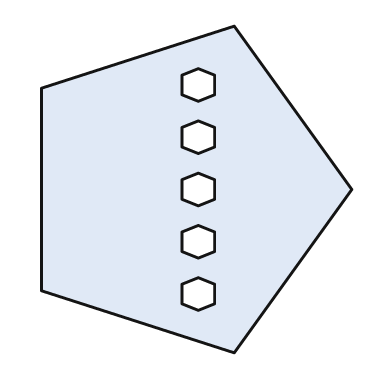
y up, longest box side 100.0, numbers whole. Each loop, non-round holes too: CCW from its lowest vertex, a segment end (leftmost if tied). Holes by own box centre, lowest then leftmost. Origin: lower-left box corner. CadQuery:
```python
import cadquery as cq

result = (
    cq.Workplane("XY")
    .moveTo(59.0, 0.0)
    .lineTo(95.0, 50.0)
    .lineTo(59.0, 100.0)
    .lineTo(0.0, 81.0)
    .lineTo(0.0, 19.0)
    .close()
    .moveTo(48.0, 13.0)
    .lineTo(53.0, 15.0)
    .lineTo(53.0, 21.0)
    .lineTo(48.0, 23.0)
    .lineTo(43.0, 21.0)
    .lineTo(43.0, 15.0)
    .close()
    .moveTo(48.0, 29.0)
    .lineTo(53.0, 31.0)
    .lineTo(53.0, 37.0)
    .lineTo(48.0, 39.0)
    .lineTo(43.0, 37.0)
    .lineTo(43.0, 31.0)
    .close()
    .moveTo(48.0, 45.0)
    .lineTo(53.0, 47.0)
    .lineTo(53.0, 53.0)
    .lineTo(48.0, 55.0)
    .lineTo(43.0, 53.0)
    .lineTo(43.0, 47.0)
    .close()
    .moveTo(48.0, 61.0)
    .lineTo(53.0, 63.0)
    .lineTo(53.0, 69.0)
    .lineTo(48.0, 71.0)
    .lineTo(43.0, 69.0)
    .lineTo(43.0, 63.0)
    .close()
    .moveTo(48.0, 77.0)
    .lineTo(53.0, 79.0)
    .lineTo(53.0, 85.0)
    .lineTo(48.0, 87.0)
    .lineTo(43.0, 85.0)
    .lineTo(43.0, 79.0)
    .close()
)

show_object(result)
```